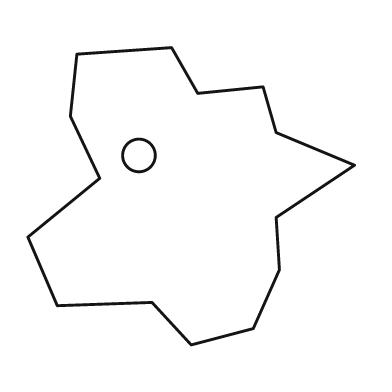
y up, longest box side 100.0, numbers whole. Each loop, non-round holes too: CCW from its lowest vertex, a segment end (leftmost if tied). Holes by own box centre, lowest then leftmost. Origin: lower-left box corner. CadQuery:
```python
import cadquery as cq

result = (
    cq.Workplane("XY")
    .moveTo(50.0, 0.0)
    .lineTo(69.0, 5.0)
    .lineTo(77.0, 23.0)
    .lineTo(76.0, 39.0)
    .lineTo(100.0, 55.0)
    .lineTo(76.0, 65.0)
    .lineTo(72.0, 79.0)
    .lineTo(52.0, 77.0)
    .lineTo(44.0, 91.0)
    .lineTo(15.0, 89.0)
    .lineTo(13.0, 70.0)
    .lineTo(22.0, 51.0)
    .lineTo(0.0, 33.0)
    .lineTo(9.0, 12.0)
    .lineTo(38.0, 13.0)
    .close()
    .moveTo(34.0, 58.0)
    .circle(5.0)
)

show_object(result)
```